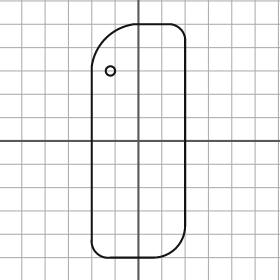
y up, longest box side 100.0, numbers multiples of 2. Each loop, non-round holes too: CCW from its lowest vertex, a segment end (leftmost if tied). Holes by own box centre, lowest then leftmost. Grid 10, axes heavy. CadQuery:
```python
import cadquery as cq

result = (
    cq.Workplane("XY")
    .moveTo(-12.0, -50.0)
    .lineTo(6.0, -50.0)
    .threePointArc((16.0, -46.0), (20.0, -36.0))
    .lineTo(20.0, 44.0)
    .threePointArc((18.0, 48.0), (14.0, 50.0))
    .lineTo(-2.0, 50.0)
    .threePointArc((-14.0, 44.0), (-20.0, 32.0))
    .lineTo(-20.0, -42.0)
    .threePointArc((-18.0, -48.0), (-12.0, -50.0))
    .close()
    .moveTo(-12.0, 30.0)
    .circle(2.0)
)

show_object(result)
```